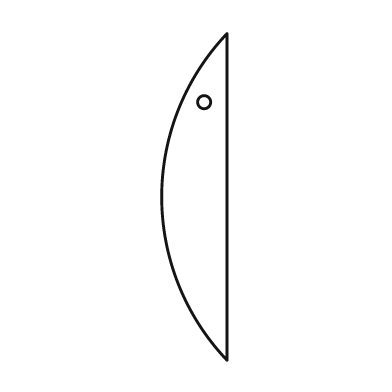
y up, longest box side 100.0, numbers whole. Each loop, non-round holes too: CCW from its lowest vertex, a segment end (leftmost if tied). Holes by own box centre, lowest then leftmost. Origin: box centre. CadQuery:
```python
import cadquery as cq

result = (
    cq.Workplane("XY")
    .moveTo(10.0, -50.0)
    .lineTo(10.0, 50.0)
    .threePointArc((-10.0, 0.0), (10.0, -50.0))
    .close()
    .moveTo(3.0, 29.0)
    .circle(2.0)
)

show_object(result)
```